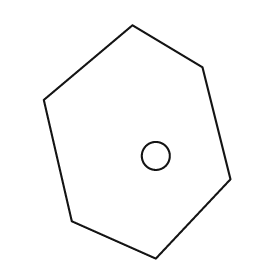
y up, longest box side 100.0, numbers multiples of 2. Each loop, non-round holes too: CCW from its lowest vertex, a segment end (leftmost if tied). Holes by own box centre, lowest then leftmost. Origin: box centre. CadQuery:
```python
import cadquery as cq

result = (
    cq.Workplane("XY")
    .moveTo(8.0, -50.0)
    .lineTo(40.0, -16.0)
    .lineTo(28.0, 32.0)
    .lineTo(-2.0, 50.0)
    .lineTo(-40.0, 18.0)
    .lineTo(-28.0, -34.0)
    .close()
    .moveTo(8.0, -6.0)
    .circle(6.0)
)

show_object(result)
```